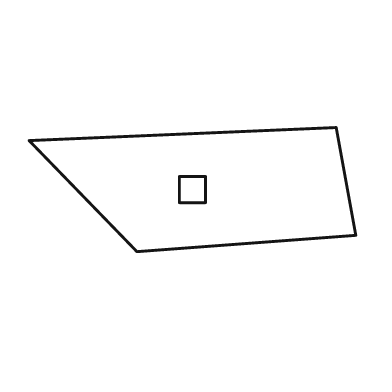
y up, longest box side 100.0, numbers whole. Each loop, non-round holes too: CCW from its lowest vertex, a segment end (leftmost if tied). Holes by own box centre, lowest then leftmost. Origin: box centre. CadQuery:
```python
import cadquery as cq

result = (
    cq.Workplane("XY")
    .moveTo(-17.0, -19.0)
    .lineTo(50.0, -14.0)
    .lineTo(44.0, 19.0)
    .lineTo(-50.0, 15.0)
    .close()
    .moveTo(-4.0, -4.0)
    .lineTo(4.0, -4.0)
    .lineTo(4.0, 4.0)
    .lineTo(-4.0, 4.0)
    .close()
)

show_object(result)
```